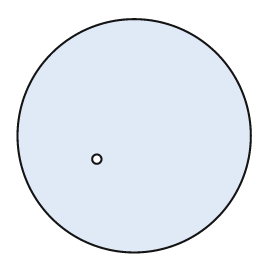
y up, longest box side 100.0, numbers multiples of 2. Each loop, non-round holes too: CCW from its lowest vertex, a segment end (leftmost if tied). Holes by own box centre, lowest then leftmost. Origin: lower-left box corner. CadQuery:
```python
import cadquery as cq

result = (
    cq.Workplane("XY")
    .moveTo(50.0, 50.0)
    .circle(50.0)
    .moveTo(34.0, 40.0)
    .circle(2.0)
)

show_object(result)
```